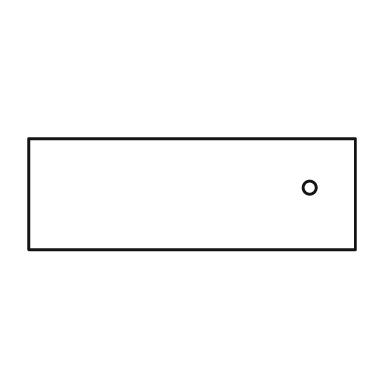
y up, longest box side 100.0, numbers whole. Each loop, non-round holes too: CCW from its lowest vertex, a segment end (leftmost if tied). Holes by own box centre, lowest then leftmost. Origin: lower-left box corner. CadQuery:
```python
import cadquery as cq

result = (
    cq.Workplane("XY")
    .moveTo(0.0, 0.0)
    .lineTo(100.0, 0.0)
    .lineTo(100.0, 34.0)
    .lineTo(0.0, 34.0)
    .close()
    .moveTo(86.0, 19.0)
    .circle(2.0)
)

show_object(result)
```